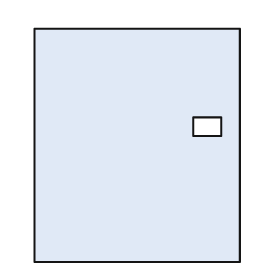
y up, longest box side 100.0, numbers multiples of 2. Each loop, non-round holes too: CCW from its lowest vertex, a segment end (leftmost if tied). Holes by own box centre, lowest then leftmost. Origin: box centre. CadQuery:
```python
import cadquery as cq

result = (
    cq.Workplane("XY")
    .moveTo(-44.0, -50.0)
    .lineTo(44.0, -50.0)
    .lineTo(44.0, 50.0)
    .lineTo(-44.0, 50.0)
    .close()
    .moveTo(24.0, 4.0)
    .lineTo(36.0, 4.0)
    .lineTo(36.0, 12.0)
    .lineTo(24.0, 12.0)
    .close()
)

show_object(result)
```